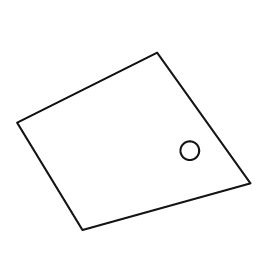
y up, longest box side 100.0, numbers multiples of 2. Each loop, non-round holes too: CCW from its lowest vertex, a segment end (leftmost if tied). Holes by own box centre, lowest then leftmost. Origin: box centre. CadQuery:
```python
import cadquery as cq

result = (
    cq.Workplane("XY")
    .moveTo(-22.0, -38.0)
    .lineTo(50.0, -18.0)
    .lineTo(10.0, 38.0)
    .lineTo(-50.0, 8.0)
    .close()
    .moveTo(24.0, -4.0)
    .circle(4.0)
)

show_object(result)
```